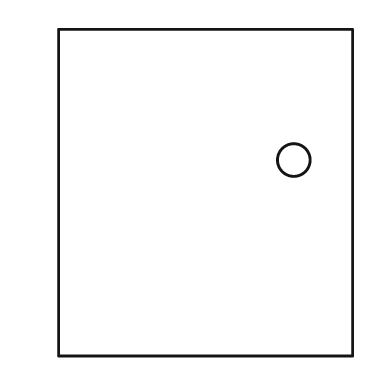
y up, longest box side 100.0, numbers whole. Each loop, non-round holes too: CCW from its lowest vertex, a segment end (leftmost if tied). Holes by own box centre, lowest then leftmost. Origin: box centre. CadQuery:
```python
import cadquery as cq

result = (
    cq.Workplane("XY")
    .moveTo(-45.0, -50.0)
    .lineTo(45.0, -50.0)
    .lineTo(45.0, 50.0)
    .lineTo(-45.0, 50.0)
    .close()
    .moveTo(27.0, 10.0)
    .circle(5.0)
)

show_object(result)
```